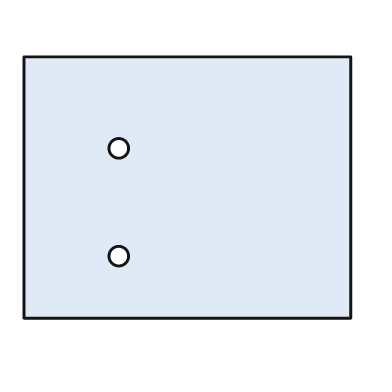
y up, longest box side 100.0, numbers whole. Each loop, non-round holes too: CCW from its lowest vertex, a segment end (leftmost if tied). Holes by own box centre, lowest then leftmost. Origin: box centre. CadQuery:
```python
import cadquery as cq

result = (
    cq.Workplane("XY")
    .moveTo(-50.0, -40.0)
    .lineTo(50.0, -40.0)
    .lineTo(50.0, 40.0)
    .lineTo(-50.0, 40.0)
    .close()
    .moveTo(-21.0, -21.0)
    .circle(3.0)
    .moveTo(-21.0, 12.0)
    .circle(3.0)
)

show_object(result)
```